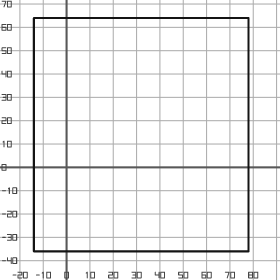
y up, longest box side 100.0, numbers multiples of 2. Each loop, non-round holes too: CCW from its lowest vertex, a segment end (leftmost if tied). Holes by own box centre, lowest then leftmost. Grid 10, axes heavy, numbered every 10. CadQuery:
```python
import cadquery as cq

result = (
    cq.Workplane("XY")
    .moveTo(-14.0, -36.0)
    .lineTo(78.0, -36.0)
    .lineTo(78.0, 64.0)
    .lineTo(-14.0, 64.0)
    .close()
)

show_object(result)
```